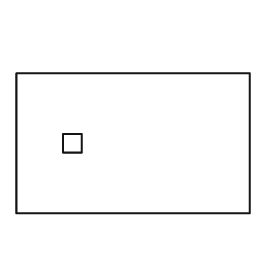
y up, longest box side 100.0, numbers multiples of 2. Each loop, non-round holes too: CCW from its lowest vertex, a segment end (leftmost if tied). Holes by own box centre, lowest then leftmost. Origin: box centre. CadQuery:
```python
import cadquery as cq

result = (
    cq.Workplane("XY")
    .moveTo(-50.0, -30.0)
    .lineTo(50.0, -30.0)
    .lineTo(50.0, 30.0)
    .lineTo(-50.0, 30.0)
    .close()
    .moveTo(-30.0, -4.0)
    .lineTo(-22.0, -4.0)
    .lineTo(-22.0, 4.0)
    .lineTo(-30.0, 4.0)
    .close()
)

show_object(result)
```